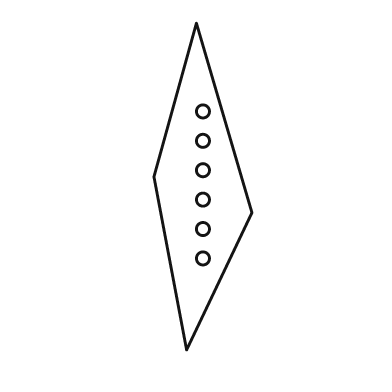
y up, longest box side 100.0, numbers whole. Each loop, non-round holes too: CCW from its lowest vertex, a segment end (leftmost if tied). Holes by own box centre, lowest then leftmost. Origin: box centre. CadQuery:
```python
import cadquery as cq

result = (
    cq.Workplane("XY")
    .moveTo(-5.0, -50.0)
    .lineTo(15.0, -8.0)
    .lineTo(-2.0, 50.0)
    .lineTo(-15.0, 3.0)
    .close()
    .moveTo(0.0, -22.0)
    .circle(2.0)
    .moveTo(0.0, -13.0)
    .circle(2.0)
    .moveTo(0.0, -4.0)
    .circle(2.0)
    .moveTo(0.0, 5.0)
    .circle(2.0)
    .moveTo(0.0, 14.0)
    .circle(2.0)
    .moveTo(0.0, 23.0)
    .circle(2.0)
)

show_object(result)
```